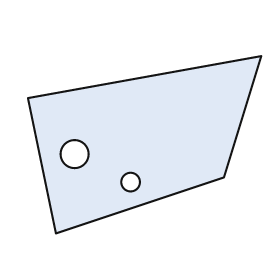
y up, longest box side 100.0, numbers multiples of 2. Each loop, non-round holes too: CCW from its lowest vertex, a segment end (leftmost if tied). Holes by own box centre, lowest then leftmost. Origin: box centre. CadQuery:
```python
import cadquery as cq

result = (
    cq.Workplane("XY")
    .moveTo(-38.0, -38.0)
    .lineTo(34.0, -14.0)
    .lineTo(50.0, 38.0)
    .lineTo(-50.0, 20.0)
    .close()
    .moveTo(-6.0, -16.0)
    .circle(4.0)
    .moveTo(-30.0, -4.0)
    .circle(6.0)
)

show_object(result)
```